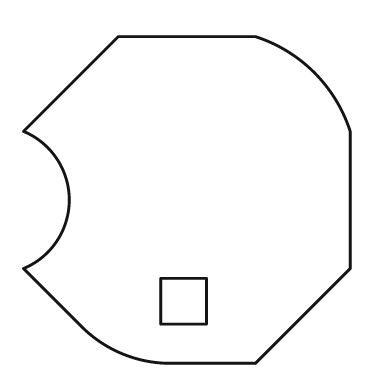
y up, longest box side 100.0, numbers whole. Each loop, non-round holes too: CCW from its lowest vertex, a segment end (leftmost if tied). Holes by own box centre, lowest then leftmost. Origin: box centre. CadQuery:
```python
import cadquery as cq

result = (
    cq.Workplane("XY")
    .moveTo(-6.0, -50.0)
    .lineTo(21.0, -50.0)
    .lineTo(50.0, -21.0)
    .lineTo(50.0, 21.0)
    .threePointArc((39.0, 39.0), (21.0, 50.0))
    .lineTo(-21.0, 50.0)
    .lineTo(-50.0, 21.0)
    .threePointArc((-36.0, 0.0), (-50.0, -21.0))
    .lineTo(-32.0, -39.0)
    .threePointArc((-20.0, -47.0), (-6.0, -50.0))
    .close()
    .moveTo(-8.0, -38.0)
    .lineTo(6.0, -38.0)
    .lineTo(6.0, -24.0)
    .lineTo(-8.0, -24.0)
    .close()
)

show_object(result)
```